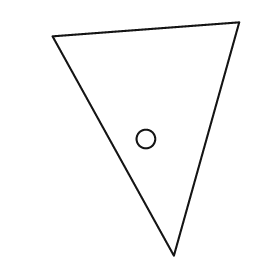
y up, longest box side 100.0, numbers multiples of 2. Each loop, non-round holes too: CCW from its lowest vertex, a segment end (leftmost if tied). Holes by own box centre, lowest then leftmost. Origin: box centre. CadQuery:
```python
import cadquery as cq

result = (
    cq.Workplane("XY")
    .moveTo(12.0, -50.0)
    .lineTo(40.0, 50.0)
    .lineTo(-40.0, 44.0)
    .close()
    .moveTo(0.0, 0.0)
    .circle(4.0)
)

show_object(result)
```